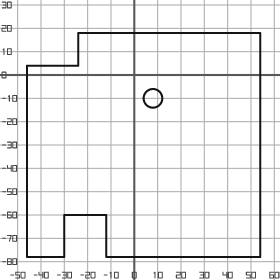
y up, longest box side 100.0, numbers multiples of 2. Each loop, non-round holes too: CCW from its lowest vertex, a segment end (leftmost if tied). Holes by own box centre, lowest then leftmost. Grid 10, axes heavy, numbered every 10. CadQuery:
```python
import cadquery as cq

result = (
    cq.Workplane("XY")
    .moveTo(-46.0, -78.0)
    .lineTo(-30.0, -78.0)
    .lineTo(-30.0, -60.0)
    .lineTo(-12.0, -60.0)
    .lineTo(-12.0, -78.0)
    .lineTo(54.0, -78.0)
    .lineTo(54.0, 18.0)
    .lineTo(-24.0, 18.0)
    .lineTo(-24.0, 4.0)
    .lineTo(-46.0, 4.0)
    .close()
    .moveTo(8.0, -10.0)
    .circle(4.0)
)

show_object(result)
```